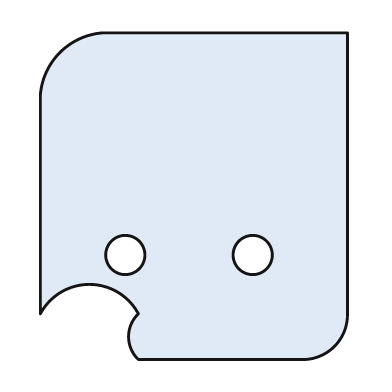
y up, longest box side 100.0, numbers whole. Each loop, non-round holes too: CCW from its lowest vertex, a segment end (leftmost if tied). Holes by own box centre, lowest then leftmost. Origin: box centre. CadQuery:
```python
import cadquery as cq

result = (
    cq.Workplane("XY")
    .moveTo(-17.0, -50.0)
    .lineTo(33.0, -50.0)
    .threePointArc((43.0, -46.0), (47.0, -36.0))
    .lineTo(47.0, 50.0)
    .lineTo(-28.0, 50.0)
    .threePointArc((-41.0, 44.0), (-47.0, 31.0))
    .lineTo(-47.0, -36.0)
    .threePointArc((-32.0, -27.0), (-17.0, -36.0))
    .threePointArc((-20.0, -43.0), (-17.0, -50.0))
    .close()
    .moveTo(-21.0, -18.0)
    .circle(6.0)
    .moveTo(18.0, -18.0)
    .circle(6.0)
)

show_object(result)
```